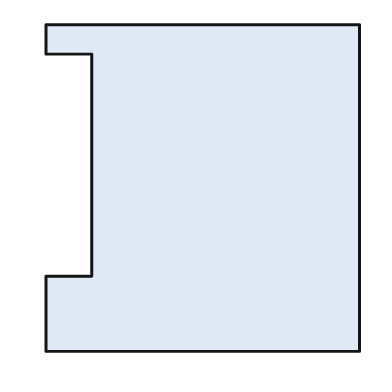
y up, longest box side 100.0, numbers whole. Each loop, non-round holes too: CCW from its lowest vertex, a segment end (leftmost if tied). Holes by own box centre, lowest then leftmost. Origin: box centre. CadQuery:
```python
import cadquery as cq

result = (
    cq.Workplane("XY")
    .moveTo(-48.0, -50.0)
    .lineTo(48.0, -50.0)
    .lineTo(48.0, 50.0)
    .lineTo(-48.0, 50.0)
    .lineTo(-48.0, 41.0)
    .lineTo(-34.0, 41.0)
    .lineTo(-34.0, -27.0)
    .lineTo(-48.0, -27.0)
    .close()
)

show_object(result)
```